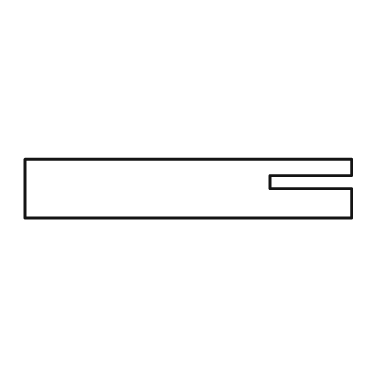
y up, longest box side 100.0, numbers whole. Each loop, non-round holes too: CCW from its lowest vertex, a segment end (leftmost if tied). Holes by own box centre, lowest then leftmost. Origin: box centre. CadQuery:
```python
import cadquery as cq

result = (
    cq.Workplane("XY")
    .moveTo(-50.0, -9.0)
    .lineTo(50.0, -9.0)
    .lineTo(50.0, 0.0)
    .lineTo(25.0, 0.0)
    .lineTo(25.0, 4.0)
    .lineTo(50.0, 4.0)
    .lineTo(50.0, 9.0)
    .lineTo(-50.0, 9.0)
    .close()
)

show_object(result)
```